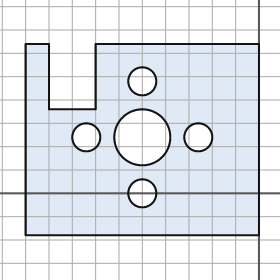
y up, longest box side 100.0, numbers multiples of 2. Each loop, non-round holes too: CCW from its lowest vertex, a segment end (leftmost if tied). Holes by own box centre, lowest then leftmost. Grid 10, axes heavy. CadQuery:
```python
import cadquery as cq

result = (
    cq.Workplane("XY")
    .moveTo(-100.0, -18.0)
    .lineTo(0.0, -18.0)
    .lineTo(0.0, 64.0)
    .lineTo(-70.0, 64.0)
    .lineTo(-70.0, 36.0)
    .lineTo(-90.0, 36.0)
    .lineTo(-90.0, 64.0)
    .lineTo(-100.0, 64.0)
    .close()
    .moveTo(-50.0, 0.0)
    .circle(6.0)
    .moveTo(-74.0, 24.0)
    .circle(6.0)
    .moveTo(-50.0, 24.0)
    .circle(12.0)
    .moveTo(-26.0, 24.0)
    .circle(6.0)
    .moveTo(-50.0, 48.0)
    .circle(6.0)
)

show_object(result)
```